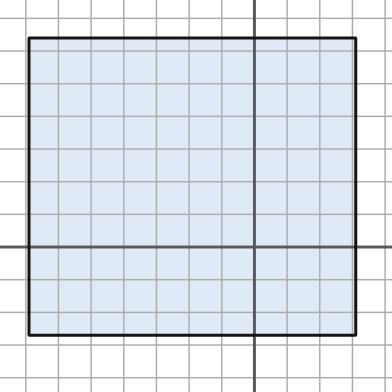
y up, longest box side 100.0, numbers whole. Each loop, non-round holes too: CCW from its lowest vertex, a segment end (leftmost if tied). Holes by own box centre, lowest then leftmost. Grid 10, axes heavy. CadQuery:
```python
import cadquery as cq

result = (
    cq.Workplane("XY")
    .moveTo(-69.0, -27.0)
    .lineTo(31.0, -27.0)
    .lineTo(31.0, 64.0)
    .lineTo(-69.0, 64.0)
    .close()
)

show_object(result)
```